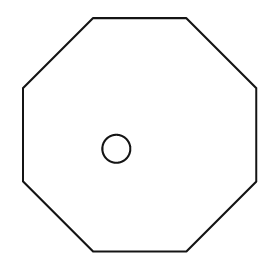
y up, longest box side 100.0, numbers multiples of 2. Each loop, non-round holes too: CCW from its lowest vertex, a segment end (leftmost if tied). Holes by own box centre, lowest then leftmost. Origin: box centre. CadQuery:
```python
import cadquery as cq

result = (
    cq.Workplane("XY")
    .moveTo(-20.0, -50.0)
    .lineTo(20.0, -50.0)
    .lineTo(50.0, -20.0)
    .lineTo(50.0, 20.0)
    .lineTo(20.0, 50.0)
    .lineTo(-20.0, 50.0)
    .lineTo(-50.0, 20.0)
    .lineTo(-50.0, -20.0)
    .close()
    .moveTo(-10.0, -6.0)
    .circle(6.0)
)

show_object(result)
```